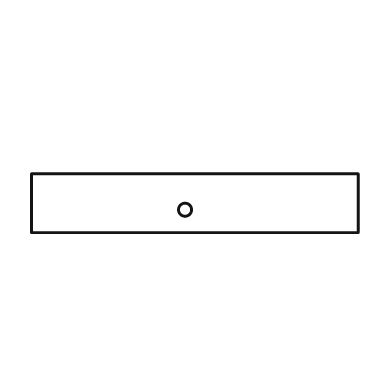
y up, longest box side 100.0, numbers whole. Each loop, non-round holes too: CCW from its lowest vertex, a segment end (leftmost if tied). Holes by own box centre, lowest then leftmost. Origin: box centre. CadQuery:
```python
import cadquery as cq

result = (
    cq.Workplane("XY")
    .moveTo(-50.0, -9.0)
    .lineTo(50.0, -9.0)
    .lineTo(50.0, 9.0)
    .lineTo(-50.0, 9.0)
    .close()
    .moveTo(-3.0, -2.0)
    .circle(2.0)
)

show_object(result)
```